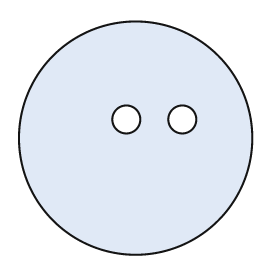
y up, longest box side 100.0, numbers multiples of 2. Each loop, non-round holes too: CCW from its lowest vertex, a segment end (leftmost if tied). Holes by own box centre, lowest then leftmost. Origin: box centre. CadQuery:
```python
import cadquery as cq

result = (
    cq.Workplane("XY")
    .moveTo(0.0, 0.0)
    .circle(50.0)
    .moveTo(-4.0, 8.0)
    .circle(6.0)
    .moveTo(20.0, 8.0)
    .circle(6.0)
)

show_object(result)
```